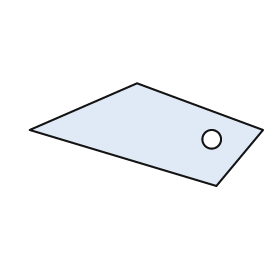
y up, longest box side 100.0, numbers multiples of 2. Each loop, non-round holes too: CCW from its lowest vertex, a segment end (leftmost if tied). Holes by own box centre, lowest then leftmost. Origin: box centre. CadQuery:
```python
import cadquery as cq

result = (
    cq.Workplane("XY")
    .moveTo(30.0, -22.0)
    .lineTo(50.0, 2.0)
    .lineTo(-4.0, 22.0)
    .lineTo(-50.0, 2.0)
    .close()
    .moveTo(28.0, -2.0)
    .circle(4.0)
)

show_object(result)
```